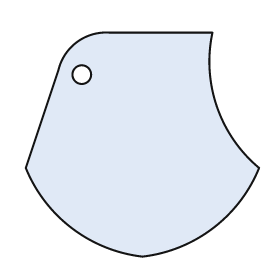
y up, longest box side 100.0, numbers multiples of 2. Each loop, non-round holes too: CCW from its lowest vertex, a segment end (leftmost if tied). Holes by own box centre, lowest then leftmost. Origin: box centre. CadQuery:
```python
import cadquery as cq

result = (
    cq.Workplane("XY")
    .moveTo(0.0, -48.0)
    .threePointArc((30.0, -36.0), (50.0, -10.0))
    .threePointArc((32.0, 16.0), (30.0, 48.0))
    .lineTo(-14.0, 48.0)
    .threePointArc((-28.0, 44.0), (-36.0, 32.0))
    .lineTo(-50.0, -10.0)
    .threePointArc((-30.0, -36.0), (0.0, -48.0))
    .close()
    .moveTo(-26.0, 30.0)
    .circle(4.0)
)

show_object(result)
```